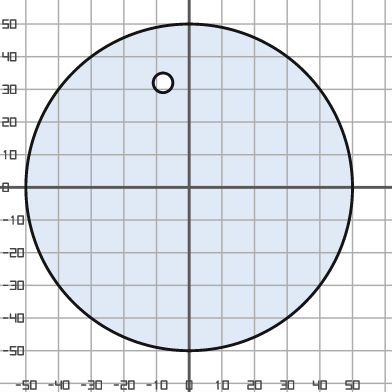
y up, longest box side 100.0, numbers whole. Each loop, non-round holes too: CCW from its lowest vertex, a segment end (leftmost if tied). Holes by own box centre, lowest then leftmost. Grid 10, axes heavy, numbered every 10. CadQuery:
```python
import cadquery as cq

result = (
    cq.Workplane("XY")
    .moveTo(0.0, 0.0)
    .circle(50.0)
    .moveTo(-8.0, 32.0)
    .circle(3.0)
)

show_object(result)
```